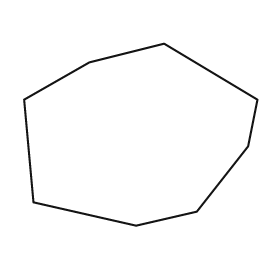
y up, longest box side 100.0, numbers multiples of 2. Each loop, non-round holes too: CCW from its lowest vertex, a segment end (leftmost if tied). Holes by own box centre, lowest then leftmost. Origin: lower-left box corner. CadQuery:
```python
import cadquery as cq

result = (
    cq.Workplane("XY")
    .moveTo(48.0, 0.0)
    .lineTo(74.0, 6.0)
    .lineTo(96.0, 34.0)
    .lineTo(100.0, 54.0)
    .lineTo(60.0, 78.0)
    .lineTo(28.0, 70.0)
    .lineTo(0.0, 54.0)
    .lineTo(4.0, 10.0)
    .close()
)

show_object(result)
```